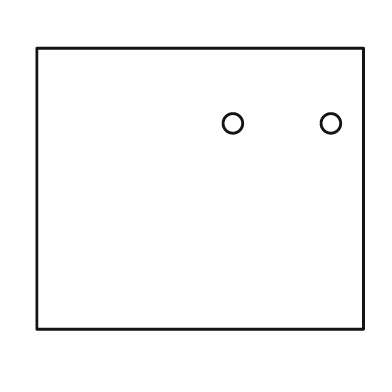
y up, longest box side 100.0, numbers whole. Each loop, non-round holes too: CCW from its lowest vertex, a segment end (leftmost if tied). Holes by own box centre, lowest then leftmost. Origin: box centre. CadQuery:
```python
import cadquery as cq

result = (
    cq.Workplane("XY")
    .moveTo(-50.0, -43.0)
    .lineTo(50.0, -43.0)
    .lineTo(50.0, 43.0)
    .lineTo(-50.0, 43.0)
    .close()
    .moveTo(10.0, 20.0)
    .circle(3.0)
    .moveTo(40.0, 20.0)
    .circle(3.0)
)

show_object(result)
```